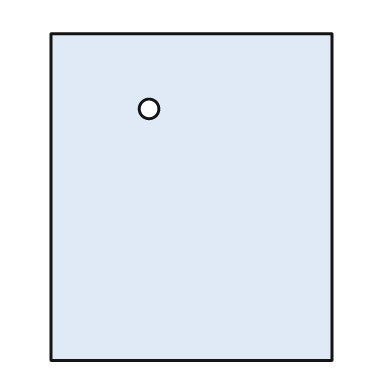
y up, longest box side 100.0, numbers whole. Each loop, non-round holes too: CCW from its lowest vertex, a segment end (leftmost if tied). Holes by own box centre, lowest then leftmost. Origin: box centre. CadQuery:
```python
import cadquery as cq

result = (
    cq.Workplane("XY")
    .moveTo(-43.0, -50.0)
    .lineTo(43.0, -50.0)
    .lineTo(43.0, 50.0)
    .lineTo(-43.0, 50.0)
    .close()
    .moveTo(-13.0, 27.0)
    .circle(3.0)
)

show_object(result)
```